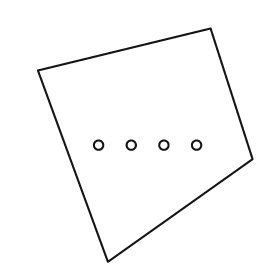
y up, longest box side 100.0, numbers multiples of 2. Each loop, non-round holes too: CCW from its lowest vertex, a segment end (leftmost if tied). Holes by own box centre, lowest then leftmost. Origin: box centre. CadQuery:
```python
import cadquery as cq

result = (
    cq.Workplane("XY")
    .moveTo(-16.0, -50.0)
    .lineTo(46.0, -6.0)
    .lineTo(28.0, 50.0)
    .lineTo(-46.0, 32.0)
    .close()
    .moveTo(-20.0, 0.0)
    .circle(2.0)
    .moveTo(-6.0, 0.0)
    .circle(2.0)
    .moveTo(8.0, 0.0)
    .circle(2.0)
    .moveTo(22.0, 0.0)
    .circle(2.0)
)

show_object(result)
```